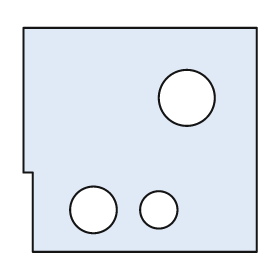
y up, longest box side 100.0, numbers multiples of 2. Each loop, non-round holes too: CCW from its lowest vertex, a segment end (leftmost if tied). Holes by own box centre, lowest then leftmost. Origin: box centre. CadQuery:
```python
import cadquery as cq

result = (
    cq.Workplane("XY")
    .moveTo(-46.0, -48.0)
    .lineTo(50.0, -48.0)
    .lineTo(50.0, 48.0)
    .lineTo(-50.0, 48.0)
    .lineTo(-50.0, -14.0)
    .lineTo(-46.0, -14.0)
    .close()
    .moveTo(-20.0, -30.0)
    .circle(10.0)
    .moveTo(8.0, -30.0)
    .circle(8.0)
    .moveTo(20.0, 18.0)
    .circle(12.0)
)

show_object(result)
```